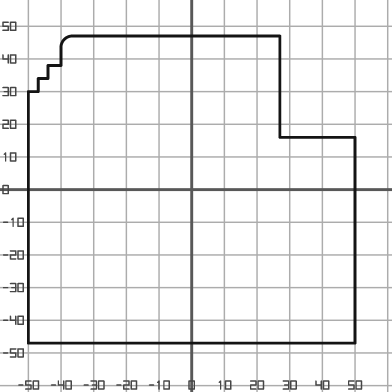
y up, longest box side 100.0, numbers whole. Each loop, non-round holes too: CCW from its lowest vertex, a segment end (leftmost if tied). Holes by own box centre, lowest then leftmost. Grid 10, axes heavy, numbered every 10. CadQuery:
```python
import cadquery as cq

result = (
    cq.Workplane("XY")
    .moveTo(-50.0, -47.0)
    .lineTo(50.0, -47.0)
    .lineTo(50.0, 16.0)
    .lineTo(27.0, 16.0)
    .lineTo(27.0, 47.0)
    .lineTo(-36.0, 47.0)
    .threePointArc((-39.0, 46.0), (-40.0, 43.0))
    .lineTo(-40.0, 38.0)
    .lineTo(-44.0, 38.0)
    .lineTo(-44.0, 34.0)
    .lineTo(-47.0, 34.0)
    .lineTo(-47.0, 30.0)
    .lineTo(-50.0, 30.0)
    .close()
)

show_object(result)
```